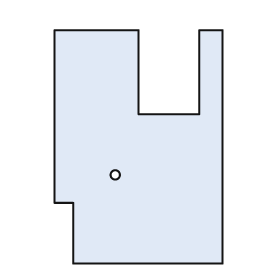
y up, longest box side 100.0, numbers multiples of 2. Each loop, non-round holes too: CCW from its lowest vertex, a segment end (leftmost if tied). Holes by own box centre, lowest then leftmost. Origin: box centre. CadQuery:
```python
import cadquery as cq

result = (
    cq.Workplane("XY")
    .moveTo(-28.0, -50.0)
    .lineTo(36.0, -50.0)
    .lineTo(36.0, 50.0)
    .lineTo(26.0, 50.0)
    .lineTo(26.0, 14.0)
    .lineTo(0.0, 14.0)
    .lineTo(0.0, 50.0)
    .lineTo(-36.0, 50.0)
    .lineTo(-36.0, -24.0)
    .lineTo(-28.0, -24.0)
    .close()
    .moveTo(-10.0, -12.0)
    .circle(2.0)
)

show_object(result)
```